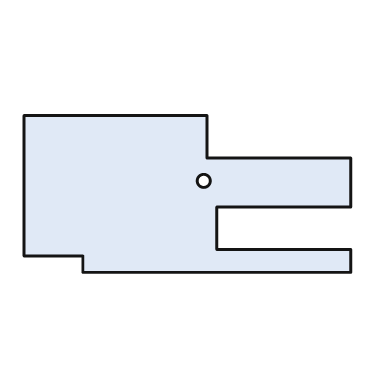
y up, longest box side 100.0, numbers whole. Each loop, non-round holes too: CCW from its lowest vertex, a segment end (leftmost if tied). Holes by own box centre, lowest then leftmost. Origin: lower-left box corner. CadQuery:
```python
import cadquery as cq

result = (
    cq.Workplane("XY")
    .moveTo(18.0, 0.0)
    .lineTo(100.0, 0.0)
    .lineTo(100.0, 7.0)
    .lineTo(59.0, 7.0)
    .lineTo(59.0, 20.0)
    .lineTo(100.0, 20.0)
    .lineTo(100.0, 35.0)
    .lineTo(56.0, 35.0)
    .lineTo(56.0, 48.0)
    .lineTo(0.0, 48.0)
    .lineTo(0.0, 5.0)
    .lineTo(18.0, 5.0)
    .close()
    .moveTo(55.0, 28.0)
    .circle(2.0)
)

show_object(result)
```